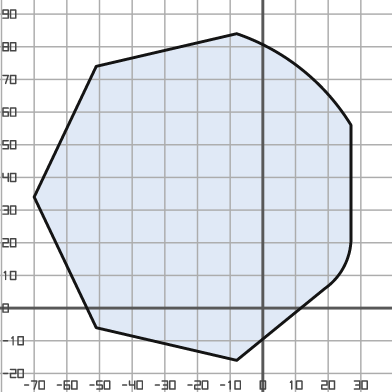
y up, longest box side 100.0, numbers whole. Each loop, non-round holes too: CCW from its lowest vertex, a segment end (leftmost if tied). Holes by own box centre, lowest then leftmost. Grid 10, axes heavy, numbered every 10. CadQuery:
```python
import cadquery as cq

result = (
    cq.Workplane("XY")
    .moveTo(-8.0, -16.0)
    .lineTo(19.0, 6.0)
    .threePointArc((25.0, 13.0), (27.0, 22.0))
    .lineTo(27.0, 56.0)
    .threePointArc((12.0, 73.0), (-8.0, 84.0))
    .lineTo(-51.0, 74.0)
    .lineTo(-70.0, 34.0)
    .lineTo(-51.0, -6.0)
    .close()
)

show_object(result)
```